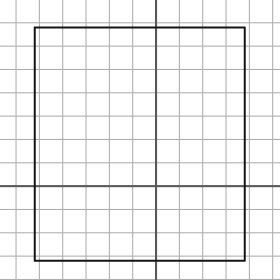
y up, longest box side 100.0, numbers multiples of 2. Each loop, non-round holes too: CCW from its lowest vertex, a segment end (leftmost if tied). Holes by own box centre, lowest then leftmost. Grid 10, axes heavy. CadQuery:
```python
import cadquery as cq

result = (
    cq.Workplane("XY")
    .moveTo(-52.0, -32.0)
    .lineTo(38.0, -32.0)
    .lineTo(38.0, 68.0)
    .lineTo(-52.0, 68.0)
    .close()
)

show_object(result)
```